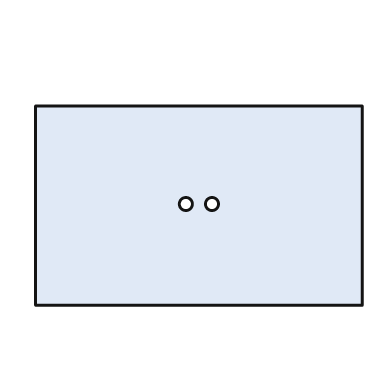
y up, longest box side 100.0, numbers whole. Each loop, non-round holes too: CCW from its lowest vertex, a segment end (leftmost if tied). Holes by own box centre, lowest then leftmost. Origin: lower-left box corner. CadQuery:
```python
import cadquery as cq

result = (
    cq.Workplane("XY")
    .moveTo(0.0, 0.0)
    .lineTo(100.0, 0.0)
    .lineTo(100.0, 61.0)
    .lineTo(0.0, 61.0)
    .close()
    .moveTo(46.0, 31.0)
    .circle(2.0)
    .moveTo(54.0, 31.0)
    .circle(2.0)
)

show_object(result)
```